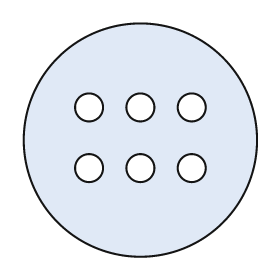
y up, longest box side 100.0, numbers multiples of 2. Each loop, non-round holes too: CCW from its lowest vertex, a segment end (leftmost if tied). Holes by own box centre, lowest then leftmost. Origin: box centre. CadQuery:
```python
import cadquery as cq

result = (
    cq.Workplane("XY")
    .moveTo(0.0, 0.0)
    .circle(50.0)
    .moveTo(-22.0, -12.0)
    .circle(6.0)
    .moveTo(0.0, -12.0)
    .circle(6.0)
    .moveTo(22.0, -12.0)
    .circle(6.0)
    .moveTo(-22.0, 14.0)
    .circle(6.0)
    .moveTo(0.0, 14.0)
    .circle(6.0)
    .moveTo(22.0, 14.0)
    .circle(6.0)
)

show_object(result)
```